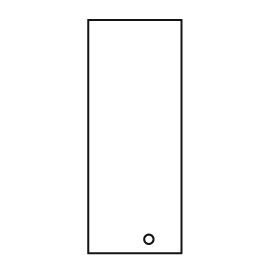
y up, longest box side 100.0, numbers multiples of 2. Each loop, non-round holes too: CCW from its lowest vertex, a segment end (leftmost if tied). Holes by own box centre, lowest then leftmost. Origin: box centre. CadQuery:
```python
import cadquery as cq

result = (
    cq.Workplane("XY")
    .moveTo(-20.0, -50.0)
    .lineTo(20.0, -50.0)
    .lineTo(20.0, 50.0)
    .lineTo(-20.0, 50.0)
    .close()
    .moveTo(6.0, -44.0)
    .circle(2.0)
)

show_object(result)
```